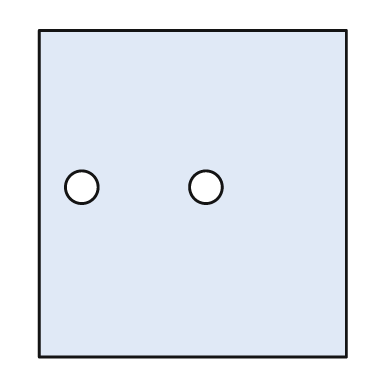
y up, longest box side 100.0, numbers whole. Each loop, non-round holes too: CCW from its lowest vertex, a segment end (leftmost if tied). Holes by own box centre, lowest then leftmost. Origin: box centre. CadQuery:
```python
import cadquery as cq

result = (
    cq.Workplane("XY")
    .moveTo(-47.0, -50.0)
    .lineTo(47.0, -50.0)
    .lineTo(47.0, 50.0)
    .lineTo(-47.0, 50.0)
    .close()
    .moveTo(-34.0, 2.0)
    .circle(5.0)
    .moveTo(4.0, 2.0)
    .circle(5.0)
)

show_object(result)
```